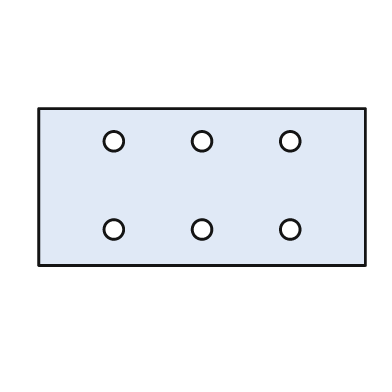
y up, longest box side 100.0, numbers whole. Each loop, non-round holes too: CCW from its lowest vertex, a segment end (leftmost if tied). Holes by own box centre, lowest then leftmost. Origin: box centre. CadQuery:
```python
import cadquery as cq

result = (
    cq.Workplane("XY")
    .moveTo(-50.0, -24.0)
    .lineTo(50.0, -24.0)
    .lineTo(50.0, 24.0)
    .lineTo(-50.0, 24.0)
    .close()
    .moveTo(-27.0, -13.0)
    .circle(3.0)
    .moveTo(0.0, -13.0)
    .circle(3.0)
    .moveTo(27.0, -13.0)
    .circle(3.0)
    .moveTo(-27.0, 14.0)
    .circle(3.0)
    .moveTo(0.0, 14.0)
    .circle(3.0)
    .moveTo(27.0, 14.0)
    .circle(3.0)
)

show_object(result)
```